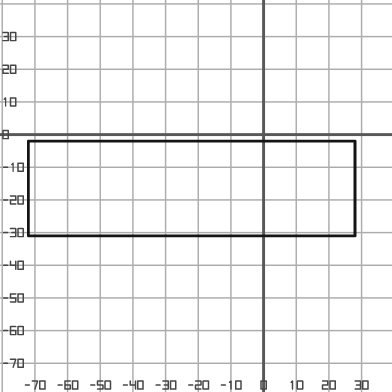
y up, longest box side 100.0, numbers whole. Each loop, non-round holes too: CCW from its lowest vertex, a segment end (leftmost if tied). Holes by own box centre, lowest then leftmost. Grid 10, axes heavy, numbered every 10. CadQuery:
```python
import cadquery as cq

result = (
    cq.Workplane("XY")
    .moveTo(-72.0, -31.0)
    .lineTo(28.0, -31.0)
    .lineTo(28.0, -2.0)
    .lineTo(-72.0, -2.0)
    .close()
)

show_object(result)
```